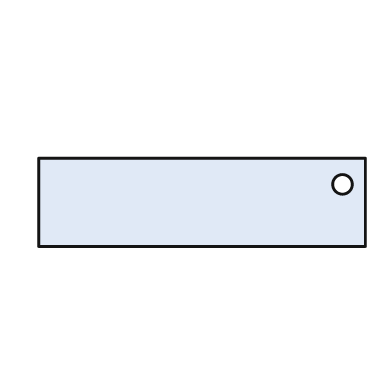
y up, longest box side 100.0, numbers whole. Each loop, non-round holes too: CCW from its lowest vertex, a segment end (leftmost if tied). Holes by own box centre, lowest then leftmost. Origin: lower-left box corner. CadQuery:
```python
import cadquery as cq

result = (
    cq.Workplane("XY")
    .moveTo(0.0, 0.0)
    .lineTo(100.0, 0.0)
    .lineTo(100.0, 27.0)
    .lineTo(0.0, 27.0)
    .close()
    .moveTo(93.0, 19.0)
    .circle(3.0)
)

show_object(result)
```